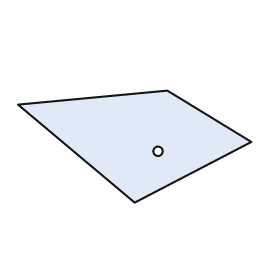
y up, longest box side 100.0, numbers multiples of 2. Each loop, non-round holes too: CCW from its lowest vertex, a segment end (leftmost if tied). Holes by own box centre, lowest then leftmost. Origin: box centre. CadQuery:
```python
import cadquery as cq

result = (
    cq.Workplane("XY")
    .moveTo(0.0, -24.0)
    .lineTo(50.0, 2.0)
    .lineTo(14.0, 24.0)
    .lineTo(-50.0, 18.0)
    .close()
    .moveTo(10.0, -2.0)
    .circle(2.0)
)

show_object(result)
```